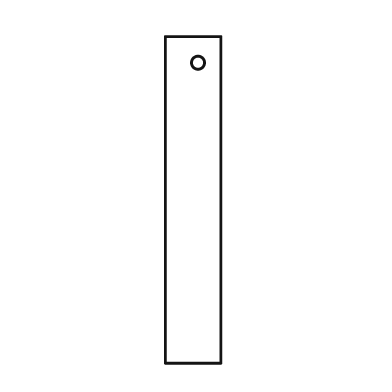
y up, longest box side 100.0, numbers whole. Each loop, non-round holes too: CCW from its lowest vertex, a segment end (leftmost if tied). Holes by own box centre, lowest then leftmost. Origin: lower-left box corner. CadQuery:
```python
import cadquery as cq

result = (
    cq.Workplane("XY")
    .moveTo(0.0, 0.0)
    .lineTo(17.0, 0.0)
    .lineTo(17.0, 100.0)
    .lineTo(0.0, 100.0)
    .close()
    .moveTo(10.0, 92.0)
    .circle(2.0)
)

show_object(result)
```